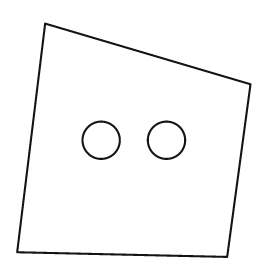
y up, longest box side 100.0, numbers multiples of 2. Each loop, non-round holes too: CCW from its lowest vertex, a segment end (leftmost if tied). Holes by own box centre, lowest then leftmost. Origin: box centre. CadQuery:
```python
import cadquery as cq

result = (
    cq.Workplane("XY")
    .moveTo(40.0, -50.0)
    .lineTo(50.0, 24.0)
    .lineTo(-38.0, 50.0)
    .lineTo(-50.0, -48.0)
    .close()
    .moveTo(-14.0, 0.0)
    .circle(8.0)
    .moveTo(14.0, 0.0)
    .circle(8.0)
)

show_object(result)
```